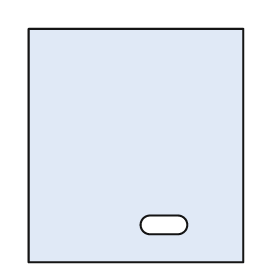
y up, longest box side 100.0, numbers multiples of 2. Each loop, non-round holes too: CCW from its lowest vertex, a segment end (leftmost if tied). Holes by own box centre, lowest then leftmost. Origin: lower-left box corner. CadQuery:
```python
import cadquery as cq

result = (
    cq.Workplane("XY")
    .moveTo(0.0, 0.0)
    .lineTo(92.0, 0.0)
    .lineTo(92.0, 100.0)
    .lineTo(0.0, 100.0)
    .close()
    .moveTo(52.0, 12.0)
    .lineTo(64.0, 12.0)
    .threePointArc((68.0, 16.0), (64.0, 20.0))
    .lineTo(52.0, 20.0)
    .threePointArc((48.0, 16.0), (52.0, 12.0))
    .close()
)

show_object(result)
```